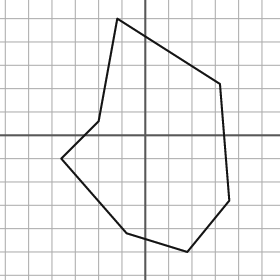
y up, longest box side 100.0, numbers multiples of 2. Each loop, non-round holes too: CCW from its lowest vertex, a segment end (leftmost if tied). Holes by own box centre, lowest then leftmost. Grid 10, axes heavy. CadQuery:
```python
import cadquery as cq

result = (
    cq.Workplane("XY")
    .moveTo(18.0, -50.0)
    .lineTo(36.0, -28.0)
    .lineTo(32.0, 22.0)
    .lineTo(-12.0, 50.0)
    .lineTo(-20.0, 6.0)
    .lineTo(-36.0, -10.0)
    .lineTo(-8.0, -42.0)
    .close()
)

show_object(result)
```